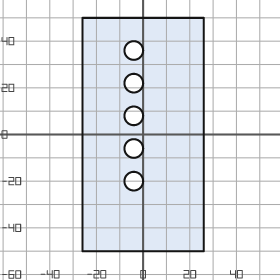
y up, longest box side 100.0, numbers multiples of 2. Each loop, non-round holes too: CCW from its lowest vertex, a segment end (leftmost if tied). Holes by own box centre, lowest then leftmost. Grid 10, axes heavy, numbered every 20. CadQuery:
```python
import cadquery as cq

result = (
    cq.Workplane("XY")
    .moveTo(-26.0, -50.0)
    .lineTo(26.0, -50.0)
    .lineTo(26.0, 50.0)
    .lineTo(-26.0, 50.0)
    .close()
    .moveTo(-4.0, -20.0)
    .circle(4.0)
    .moveTo(-4.0, -6.0)
    .circle(4.0)
    .moveTo(-4.0, 8.0)
    .circle(4.0)
    .moveTo(-4.0, 22.0)
    .circle(4.0)
    .moveTo(-4.0, 36.0)
    .circle(4.0)
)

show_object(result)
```